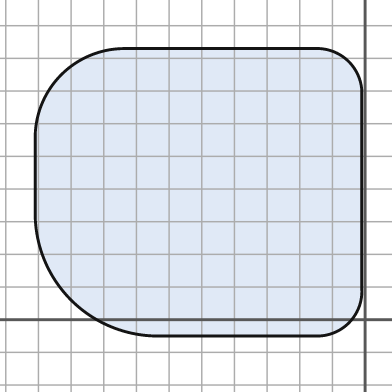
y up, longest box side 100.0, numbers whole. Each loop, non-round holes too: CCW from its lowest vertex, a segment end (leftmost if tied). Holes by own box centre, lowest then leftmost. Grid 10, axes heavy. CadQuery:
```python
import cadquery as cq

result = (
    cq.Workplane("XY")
    .moveTo(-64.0, -5.0)
    .lineTo(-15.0, -5.0)
    .threePointArc((-5.0, -1.0), (-1.0, 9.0))
    .lineTo(-1.0, 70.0)
    .threePointArc((-5.0, 79.0), (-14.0, 83.0))
    .lineTo(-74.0, 83.0)
    .threePointArc((-93.0, 75.0), (-101.0, 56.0))
    .lineTo(-101.0, 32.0)
    .threePointArc((-90.0, 6.0), (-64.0, -5.0))
    .close()
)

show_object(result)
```